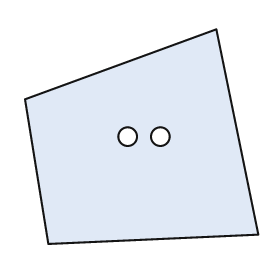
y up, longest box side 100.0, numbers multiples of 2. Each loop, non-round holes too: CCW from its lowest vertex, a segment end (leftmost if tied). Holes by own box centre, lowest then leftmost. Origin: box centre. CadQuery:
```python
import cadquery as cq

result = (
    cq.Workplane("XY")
    .moveTo(-40.0, -46.0)
    .lineTo(50.0, -42.0)
    .lineTo(32.0, 46.0)
    .lineTo(-50.0, 16.0)
    .close()
    .moveTo(-6.0, 0.0)
    .circle(4.0)
    .moveTo(8.0, 0.0)
    .circle(4.0)
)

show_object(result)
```